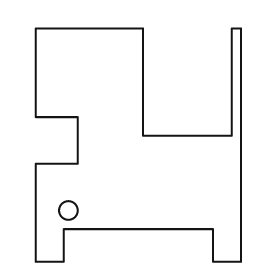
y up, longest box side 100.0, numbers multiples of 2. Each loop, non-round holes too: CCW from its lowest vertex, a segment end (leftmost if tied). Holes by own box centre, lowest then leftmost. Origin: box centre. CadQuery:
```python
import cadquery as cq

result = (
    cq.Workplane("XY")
    .moveTo(-44.0, -50.0)
    .lineTo(-32.0, -50.0)
    .lineTo(-32.0, -36.0)
    .lineTo(32.0, -36.0)
    .lineTo(32.0, -50.0)
    .lineTo(44.0, -50.0)
    .lineTo(44.0, 50.0)
    .lineTo(40.0, 50.0)
    .lineTo(40.0, 4.0)
    .lineTo(2.0, 4.0)
    .lineTo(2.0, 50.0)
    .lineTo(-44.0, 50.0)
    .lineTo(-44.0, 12.0)
    .lineTo(-26.0, 12.0)
    .lineTo(-26.0, -8.0)
    .lineTo(-44.0, -8.0)
    .close()
    .moveTo(-30.0, -28.0)
    .circle(4.0)
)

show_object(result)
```